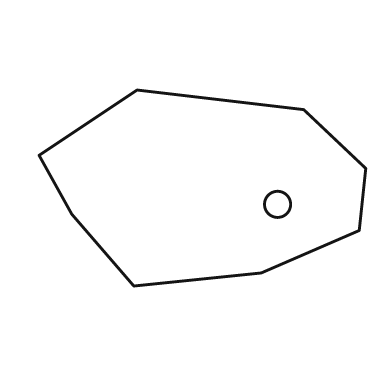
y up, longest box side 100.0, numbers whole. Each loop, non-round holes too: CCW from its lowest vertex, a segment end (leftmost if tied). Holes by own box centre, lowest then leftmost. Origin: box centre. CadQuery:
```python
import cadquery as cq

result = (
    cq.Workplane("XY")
    .moveTo(-21.0, -30.0)
    .lineTo(18.0, -26.0)
    .lineTo(48.0, -13.0)
    .lineTo(50.0, 6.0)
    .lineTo(31.0, 24.0)
    .lineTo(-20.0, 30.0)
    .lineTo(-50.0, 10.0)
    .lineTo(-40.0, -8.0)
    .close()
    .moveTo(23.0, -5.0)
    .circle(4.0)
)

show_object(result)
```